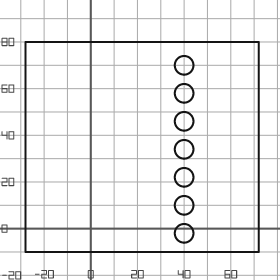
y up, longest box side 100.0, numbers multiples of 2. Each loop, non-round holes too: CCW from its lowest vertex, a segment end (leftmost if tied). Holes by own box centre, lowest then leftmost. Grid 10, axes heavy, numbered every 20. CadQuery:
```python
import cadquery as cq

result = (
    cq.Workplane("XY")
    .moveTo(-28.0, -10.0)
    .lineTo(72.0, -10.0)
    .lineTo(72.0, 80.0)
    .lineTo(-28.0, 80.0)
    .close()
    .moveTo(40.0, -2.0)
    .circle(4.0)
    .moveTo(40.0, 10.0)
    .circle(4.0)
    .moveTo(40.0, 22.0)
    .circle(4.0)
    .moveTo(40.0, 34.0)
    .circle(4.0)
    .moveTo(40.0, 46.0)
    .circle(4.0)
    .moveTo(40.0, 58.0)
    .circle(4.0)
    .moveTo(40.0, 70.0)
    .circle(4.0)
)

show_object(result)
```